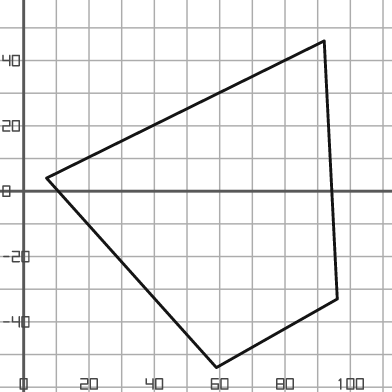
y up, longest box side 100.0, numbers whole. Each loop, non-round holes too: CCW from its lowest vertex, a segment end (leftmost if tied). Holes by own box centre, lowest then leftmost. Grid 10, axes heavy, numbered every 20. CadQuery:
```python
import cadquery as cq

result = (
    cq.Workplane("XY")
    .moveTo(59.0, -54.0)
    .lineTo(96.0, -33.0)
    .lineTo(92.0, 46.0)
    .lineTo(7.0, 4.0)
    .close()
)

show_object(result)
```